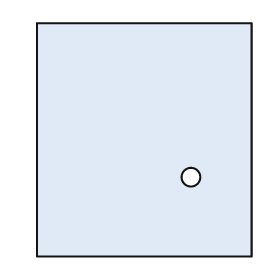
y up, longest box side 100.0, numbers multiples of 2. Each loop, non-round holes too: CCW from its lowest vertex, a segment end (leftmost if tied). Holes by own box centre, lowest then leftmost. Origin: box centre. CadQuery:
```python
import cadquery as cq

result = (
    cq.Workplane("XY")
    .moveTo(-46.0, -50.0)
    .lineTo(46.0, -50.0)
    .lineTo(46.0, 50.0)
    .lineTo(-46.0, 50.0)
    .close()
    .moveTo(20.0, -16.0)
    .circle(4.0)
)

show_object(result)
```